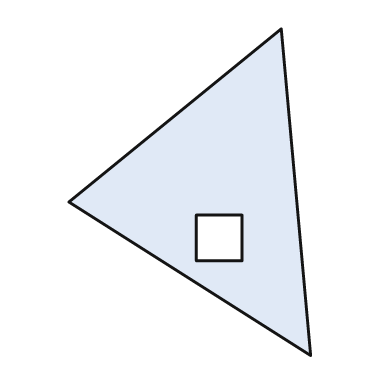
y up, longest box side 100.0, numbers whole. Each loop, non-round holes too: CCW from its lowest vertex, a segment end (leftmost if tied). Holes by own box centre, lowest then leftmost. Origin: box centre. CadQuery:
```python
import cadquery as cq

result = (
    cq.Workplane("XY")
    .moveTo(37.0, -50.0)
    .lineTo(28.0, 50.0)
    .lineTo(-37.0, -3.0)
    .close()
    .moveTo(2.0, -21.0)
    .lineTo(16.0, -21.0)
    .lineTo(16.0, -7.0)
    .lineTo(2.0, -7.0)
    .close()
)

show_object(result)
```